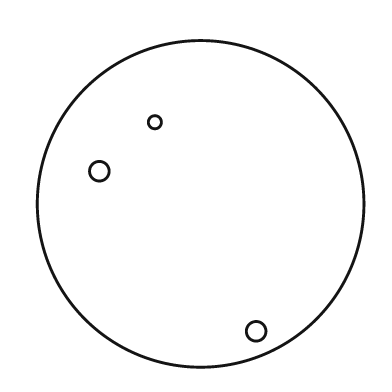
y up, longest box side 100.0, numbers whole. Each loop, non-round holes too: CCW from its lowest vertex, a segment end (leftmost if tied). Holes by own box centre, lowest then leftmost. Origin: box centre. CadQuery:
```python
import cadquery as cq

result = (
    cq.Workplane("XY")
    .moveTo(0.0, 0.0)
    .circle(50.0)
    .moveTo(17.0, -39.0)
    .circle(3.0)
    .moveTo(-31.0, 10.0)
    .circle(3.0)
    .moveTo(-14.0, 25.0)
    .circle(2.0)
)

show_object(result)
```